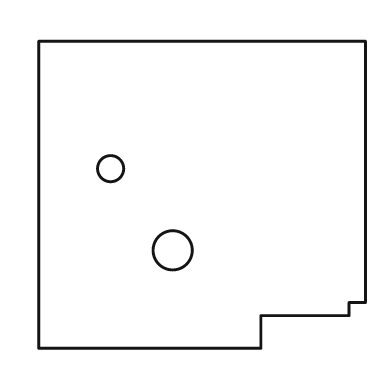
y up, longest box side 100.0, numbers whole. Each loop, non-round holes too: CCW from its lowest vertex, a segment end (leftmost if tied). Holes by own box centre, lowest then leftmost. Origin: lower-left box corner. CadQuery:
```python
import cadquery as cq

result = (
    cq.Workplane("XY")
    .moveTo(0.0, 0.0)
    .lineTo(68.0, 0.0)
    .lineTo(68.0, 10.0)
    .lineTo(95.0, 10.0)
    .lineTo(95.0, 14.0)
    .lineTo(100.0, 14.0)
    .lineTo(100.0, 94.0)
    .lineTo(0.0, 94.0)
    .close()
    .moveTo(41.0, 30.0)
    .circle(6.0)
    .moveTo(22.0, 55.0)
    .circle(4.0)
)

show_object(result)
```